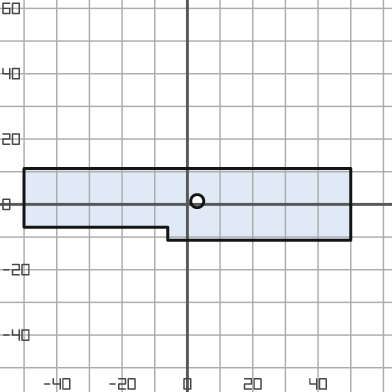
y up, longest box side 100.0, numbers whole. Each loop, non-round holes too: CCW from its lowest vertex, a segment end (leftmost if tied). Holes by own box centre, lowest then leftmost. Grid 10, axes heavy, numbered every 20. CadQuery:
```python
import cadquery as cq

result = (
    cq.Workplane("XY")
    .moveTo(-6.0, -11.0)
    .lineTo(50.0, -11.0)
    .lineTo(50.0, 11.0)
    .lineTo(-50.0, 11.0)
    .lineTo(-50.0, -7.0)
    .lineTo(-6.0, -7.0)
    .close()
    .moveTo(3.0, 1.0)
    .circle(2.0)
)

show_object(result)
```